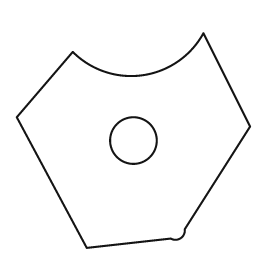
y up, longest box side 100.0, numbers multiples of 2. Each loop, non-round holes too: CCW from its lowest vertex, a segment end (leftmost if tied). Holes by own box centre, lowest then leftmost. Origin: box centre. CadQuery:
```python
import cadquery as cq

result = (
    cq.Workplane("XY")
    .moveTo(-20.0, -46.0)
    .lineTo(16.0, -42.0)
    .threePointArc((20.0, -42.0), (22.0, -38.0))
    .lineTo(50.0, 6.0)
    .lineTo(30.0, 46.0)
    .threePointArc((4.0, 28.0), (-26.0, 38.0))
    .lineTo(-50.0, 10.0)
    .close()
    .moveTo(0.0, 0.0)
    .circle(10.0)
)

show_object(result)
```